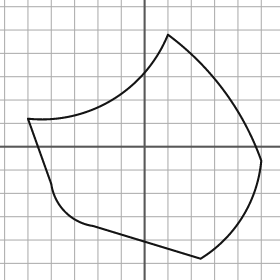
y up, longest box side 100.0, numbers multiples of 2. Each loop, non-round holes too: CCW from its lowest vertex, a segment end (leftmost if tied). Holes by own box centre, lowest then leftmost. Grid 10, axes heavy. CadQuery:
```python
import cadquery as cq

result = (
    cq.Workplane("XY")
    .moveTo(24.0, -48.0)
    .threePointArc((42.0, -30.0), (50.0, -6.0))
    .threePointArc((34.0, 24.0), (10.0, 48.0))
    .threePointArc((-14.0, 20.0), (-50.0, 12.0))
    .lineTo(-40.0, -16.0)
    .threePointArc((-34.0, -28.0), (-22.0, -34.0))
    .close()
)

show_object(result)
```